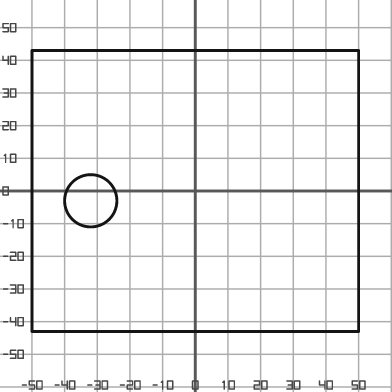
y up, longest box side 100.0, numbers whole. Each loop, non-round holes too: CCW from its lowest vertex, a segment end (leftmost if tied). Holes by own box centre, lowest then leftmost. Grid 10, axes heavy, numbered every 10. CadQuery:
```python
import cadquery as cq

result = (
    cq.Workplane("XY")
    .moveTo(-50.0, -43.0)
    .lineTo(50.0, -43.0)
    .lineTo(50.0, 43.0)
    .lineTo(-50.0, 43.0)
    .close()
    .moveTo(-32.0, -3.0)
    .circle(8.0)
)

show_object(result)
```